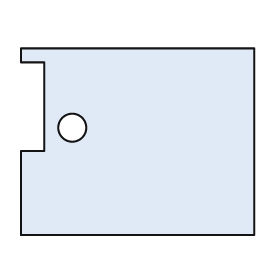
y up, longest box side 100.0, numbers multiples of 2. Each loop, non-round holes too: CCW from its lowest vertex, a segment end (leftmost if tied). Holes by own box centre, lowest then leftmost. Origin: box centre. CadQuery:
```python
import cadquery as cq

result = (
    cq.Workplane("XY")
    .moveTo(-50.0, -40.0)
    .lineTo(50.0, -40.0)
    .lineTo(50.0, 40.0)
    .lineTo(-50.0, 40.0)
    .lineTo(-50.0, 34.0)
    .lineTo(-40.0, 34.0)
    .lineTo(-40.0, -4.0)
    .lineTo(-50.0, -4.0)
    .close()
    .moveTo(-28.0, 6.0)
    .circle(6.0)
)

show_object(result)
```